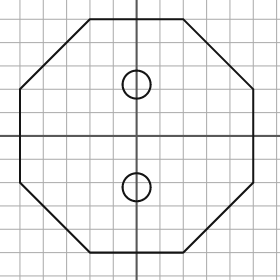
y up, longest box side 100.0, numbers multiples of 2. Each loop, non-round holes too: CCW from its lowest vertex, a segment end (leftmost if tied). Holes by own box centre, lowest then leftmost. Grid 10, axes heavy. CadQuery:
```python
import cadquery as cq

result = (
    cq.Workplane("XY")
    .moveTo(-20.0, -50.0)
    .lineTo(20.0, -50.0)
    .lineTo(50.0, -20.0)
    .lineTo(50.0, 20.0)
    .lineTo(20.0, 50.0)
    .lineTo(-20.0, 50.0)
    .lineTo(-50.0, 20.0)
    .lineTo(-50.0, -20.0)
    .close()
    .moveTo(0.0, -22.0)
    .circle(6.0)
    .moveTo(0.0, 22.0)
    .circle(6.0)
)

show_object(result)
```